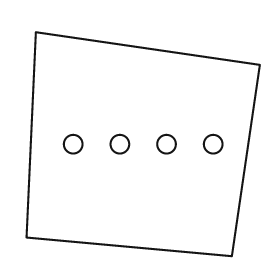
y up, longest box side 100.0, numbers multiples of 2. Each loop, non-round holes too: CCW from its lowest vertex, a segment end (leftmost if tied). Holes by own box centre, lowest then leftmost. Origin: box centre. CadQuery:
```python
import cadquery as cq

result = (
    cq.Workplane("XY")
    .moveTo(38.0, -48.0)
    .lineTo(50.0, 34.0)
    .lineTo(-46.0, 48.0)
    .lineTo(-50.0, -40.0)
    .close()
    .moveTo(-30.0, 0.0)
    .circle(4.0)
    .moveTo(-10.0, 0.0)
    .circle(4.0)
    .moveTo(10.0, 0.0)
    .circle(4.0)
    .moveTo(30.0, 0.0)
    .circle(4.0)
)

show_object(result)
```